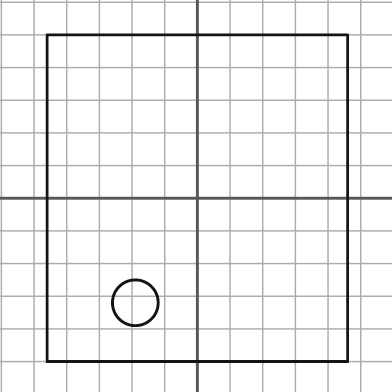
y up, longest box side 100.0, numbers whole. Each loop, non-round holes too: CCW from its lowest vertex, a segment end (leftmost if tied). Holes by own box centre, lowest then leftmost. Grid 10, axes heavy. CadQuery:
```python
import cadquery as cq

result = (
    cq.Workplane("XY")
    .moveTo(-46.0, -50.0)
    .lineTo(46.0, -50.0)
    .lineTo(46.0, 50.0)
    .lineTo(-46.0, 50.0)
    .close()
    .moveTo(-19.0, -32.0)
    .circle(7.0)
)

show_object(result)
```